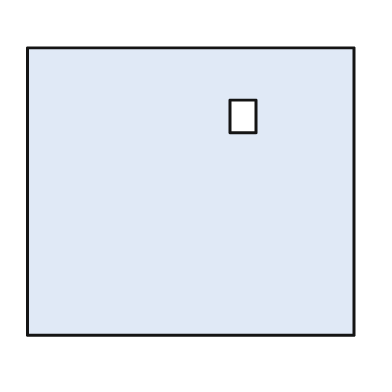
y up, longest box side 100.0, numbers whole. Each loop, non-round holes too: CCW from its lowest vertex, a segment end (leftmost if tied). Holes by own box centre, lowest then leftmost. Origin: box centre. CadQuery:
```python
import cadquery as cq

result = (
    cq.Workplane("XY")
    .moveTo(-50.0, -44.0)
    .lineTo(50.0, -44.0)
    .lineTo(50.0, 44.0)
    .lineTo(-50.0, 44.0)
    .close()
    .moveTo(12.0, 18.0)
    .lineTo(20.0, 18.0)
    .lineTo(20.0, 28.0)
    .lineTo(12.0, 28.0)
    .close()
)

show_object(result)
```